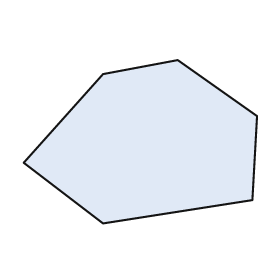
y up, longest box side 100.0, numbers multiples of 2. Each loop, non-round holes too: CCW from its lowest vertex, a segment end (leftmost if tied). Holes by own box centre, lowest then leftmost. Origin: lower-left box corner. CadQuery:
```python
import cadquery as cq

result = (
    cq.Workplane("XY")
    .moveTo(34.0, 0.0)
    .lineTo(98.0, 10.0)
    .lineTo(100.0, 46.0)
    .lineTo(66.0, 70.0)
    .lineTo(34.0, 64.0)
    .lineTo(0.0, 26.0)
    .close()
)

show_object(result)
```